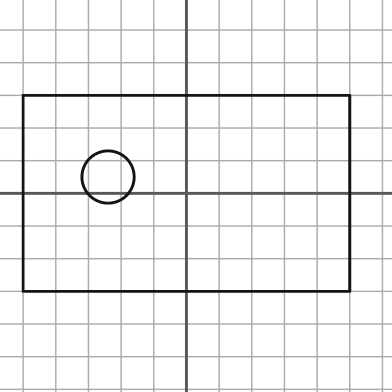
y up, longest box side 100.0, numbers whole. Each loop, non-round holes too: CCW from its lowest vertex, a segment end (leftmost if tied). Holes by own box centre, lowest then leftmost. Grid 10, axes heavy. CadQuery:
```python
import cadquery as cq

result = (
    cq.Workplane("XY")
    .moveTo(-50.0, -30.0)
    .lineTo(50.0, -30.0)
    .lineTo(50.0, 30.0)
    .lineTo(-50.0, 30.0)
    .close()
    .moveTo(-24.0, 5.0)
    .circle(8.0)
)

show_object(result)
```